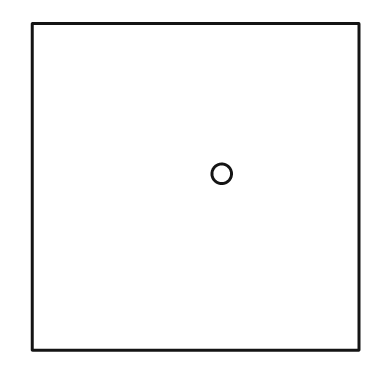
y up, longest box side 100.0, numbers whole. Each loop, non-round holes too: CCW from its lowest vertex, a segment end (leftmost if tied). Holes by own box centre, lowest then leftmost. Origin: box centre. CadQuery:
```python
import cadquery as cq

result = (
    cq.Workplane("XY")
    .moveTo(-50.0, -50.0)
    .lineTo(50.0, -50.0)
    .lineTo(50.0, 50.0)
    .lineTo(-50.0, 50.0)
    .close()
    .moveTo(8.0, 4.0)
    .circle(3.0)
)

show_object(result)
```